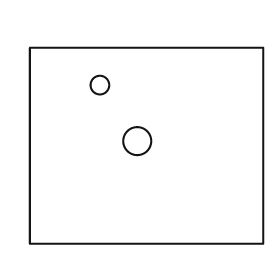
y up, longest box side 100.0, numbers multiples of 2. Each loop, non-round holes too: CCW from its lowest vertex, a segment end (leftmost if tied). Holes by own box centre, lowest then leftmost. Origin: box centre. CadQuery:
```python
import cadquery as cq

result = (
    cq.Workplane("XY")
    .moveTo(-50.0, -42.0)
    .lineTo(50.0, -42.0)
    .lineTo(50.0, 42.0)
    .lineTo(-50.0, 42.0)
    .close()
    .moveTo(-4.0, 2.0)
    .circle(6.0)
    .moveTo(-20.0, 26.0)
    .circle(4.0)
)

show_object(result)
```